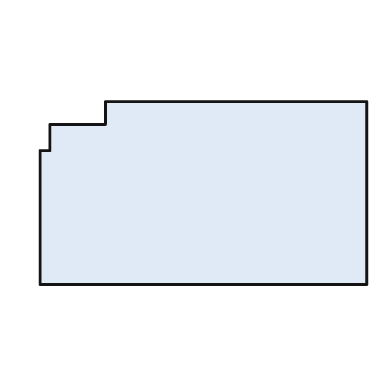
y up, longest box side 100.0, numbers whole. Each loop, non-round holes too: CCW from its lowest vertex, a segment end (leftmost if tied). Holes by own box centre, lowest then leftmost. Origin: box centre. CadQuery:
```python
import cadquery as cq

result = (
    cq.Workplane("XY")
    .moveTo(-50.0, -28.0)
    .lineTo(50.0, -28.0)
    .lineTo(50.0, 28.0)
    .lineTo(-30.0, 28.0)
    .lineTo(-30.0, 21.0)
    .lineTo(-47.0, 21.0)
    .lineTo(-47.0, 13.0)
    .lineTo(-50.0, 13.0)
    .close()
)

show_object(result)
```